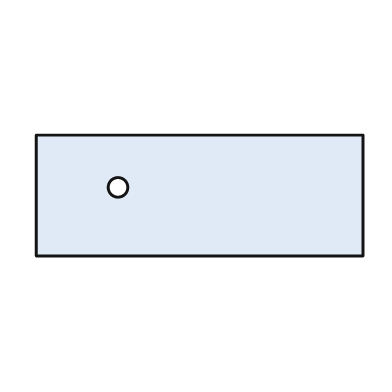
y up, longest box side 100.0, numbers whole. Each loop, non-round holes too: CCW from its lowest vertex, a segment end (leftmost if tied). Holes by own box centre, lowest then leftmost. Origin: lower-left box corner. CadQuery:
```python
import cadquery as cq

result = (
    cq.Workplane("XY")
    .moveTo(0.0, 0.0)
    .lineTo(100.0, 0.0)
    .lineTo(100.0, 37.0)
    .lineTo(0.0, 37.0)
    .close()
    .moveTo(25.0, 21.0)
    .circle(3.0)
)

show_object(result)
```